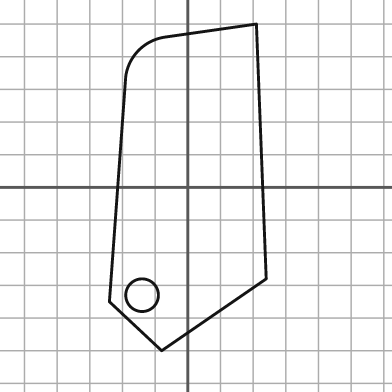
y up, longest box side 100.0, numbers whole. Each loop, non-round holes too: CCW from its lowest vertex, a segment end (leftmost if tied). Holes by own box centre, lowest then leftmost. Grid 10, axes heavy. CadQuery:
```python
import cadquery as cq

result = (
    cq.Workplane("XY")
    .moveTo(-8.0, -50.0)
    .lineTo(24.0, -28.0)
    .lineTo(21.0, 50.0)
    .lineTo(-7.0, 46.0)
    .threePointArc((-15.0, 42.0), (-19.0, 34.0))
    .lineTo(-24.0, -35.0)
    .close()
    .moveTo(-14.0, -33.0)
    .circle(5.0)
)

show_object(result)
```